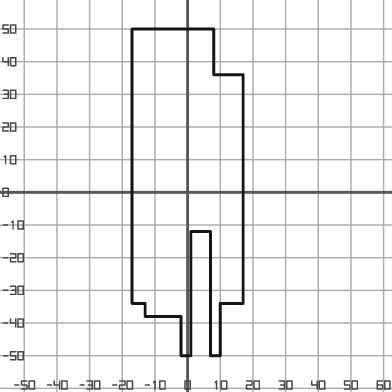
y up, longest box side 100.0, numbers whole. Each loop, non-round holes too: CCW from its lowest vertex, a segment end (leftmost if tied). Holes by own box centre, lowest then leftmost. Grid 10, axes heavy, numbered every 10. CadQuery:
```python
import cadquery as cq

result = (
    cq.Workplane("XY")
    .moveTo(-2.0, -50.0)
    .lineTo(1.0, -50.0)
    .lineTo(1.0, -12.0)
    .lineTo(7.0, -12.0)
    .lineTo(7.0, -50.0)
    .lineTo(10.0, -50.0)
    .lineTo(10.0, -34.0)
    .lineTo(17.0, -34.0)
    .lineTo(17.0, 36.0)
    .lineTo(8.0, 36.0)
    .lineTo(8.0, 50.0)
    .lineTo(-17.0, 50.0)
    .lineTo(-17.0, -34.0)
    .lineTo(-13.0, -34.0)
    .lineTo(-13.0, -38.0)
    .lineTo(-2.0, -38.0)
    .close()
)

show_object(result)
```